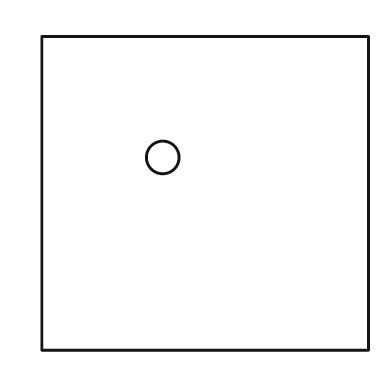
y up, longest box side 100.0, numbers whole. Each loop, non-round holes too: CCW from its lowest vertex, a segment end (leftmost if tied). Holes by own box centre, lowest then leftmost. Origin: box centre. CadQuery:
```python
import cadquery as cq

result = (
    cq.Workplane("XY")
    .moveTo(-50.0, -48.0)
    .lineTo(50.0, -48.0)
    .lineTo(50.0, 48.0)
    .lineTo(-50.0, 48.0)
    .close()
    .moveTo(-13.0, 11.0)
    .circle(5.0)
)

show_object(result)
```